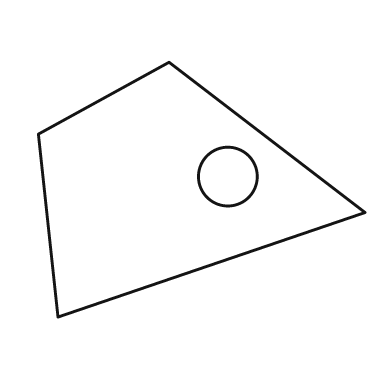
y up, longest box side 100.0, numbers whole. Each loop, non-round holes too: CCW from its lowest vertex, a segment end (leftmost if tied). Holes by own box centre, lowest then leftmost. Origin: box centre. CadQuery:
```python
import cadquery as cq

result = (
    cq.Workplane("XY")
    .moveTo(-44.0, -39.0)
    .lineTo(50.0, -7.0)
    .lineTo(-10.0, 39.0)
    .lineTo(-50.0, 17.0)
    .close()
    .moveTo(8.0, 4.0)
    .circle(9.0)
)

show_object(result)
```